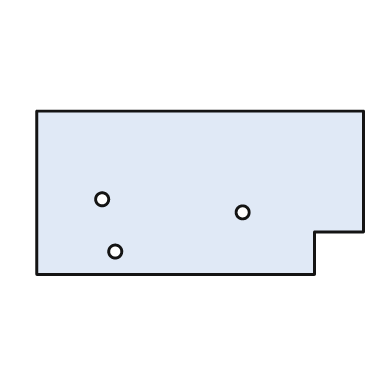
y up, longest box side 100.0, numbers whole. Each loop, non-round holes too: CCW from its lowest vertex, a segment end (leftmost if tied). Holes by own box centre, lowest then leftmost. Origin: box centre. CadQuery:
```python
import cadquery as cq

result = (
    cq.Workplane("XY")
    .moveTo(-50.0, -25.0)
    .lineTo(35.0, -25.0)
    .lineTo(35.0, -12.0)
    .lineTo(50.0, -12.0)
    .lineTo(50.0, 25.0)
    .lineTo(-50.0, 25.0)
    .close()
    .moveTo(-26.0, -18.0)
    .circle(2.0)
    .moveTo(13.0, -6.0)
    .circle(2.0)
    .moveTo(-30.0, -2.0)
    .circle(2.0)
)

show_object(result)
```